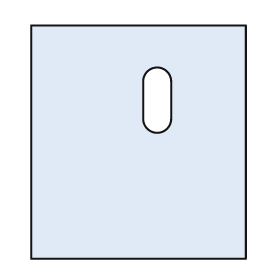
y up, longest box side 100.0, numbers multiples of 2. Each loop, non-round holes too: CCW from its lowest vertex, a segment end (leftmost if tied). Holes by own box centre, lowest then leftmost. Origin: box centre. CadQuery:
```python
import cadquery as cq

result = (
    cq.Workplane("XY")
    .moveTo(-46.0, -50.0)
    .lineTo(46.0, -50.0)
    .lineTo(46.0, 50.0)
    .lineTo(-46.0, 50.0)
    .close()
    .moveTo(2.0, 10.0)
    .threePointArc((8.0, 4.0), (14.0, 10.0))
    .lineTo(14.0, 26.0)
    .threePointArc((8.0, 32.0), (2.0, 26.0))
    .close()
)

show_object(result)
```